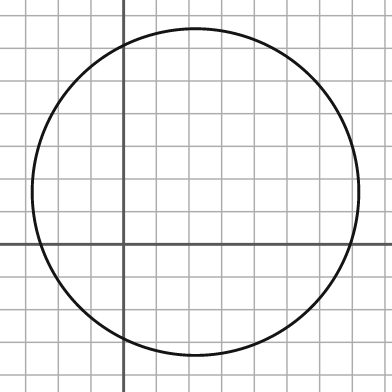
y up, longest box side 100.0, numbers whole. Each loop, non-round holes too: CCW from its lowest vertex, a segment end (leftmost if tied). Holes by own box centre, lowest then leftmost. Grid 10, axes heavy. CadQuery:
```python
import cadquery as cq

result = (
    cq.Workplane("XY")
    .moveTo(22.0, 16.0)
    .circle(50.0)
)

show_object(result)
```